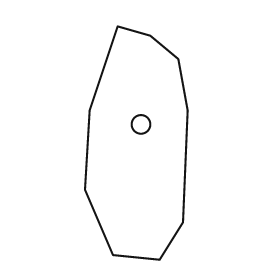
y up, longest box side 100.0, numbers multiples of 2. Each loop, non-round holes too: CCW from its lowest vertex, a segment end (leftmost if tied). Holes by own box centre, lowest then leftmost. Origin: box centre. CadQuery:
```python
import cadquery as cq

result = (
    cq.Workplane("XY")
    .moveTo(10.0, -50.0)
    .lineTo(20.0, -34.0)
    .lineTo(22.0, 14.0)
    .lineTo(18.0, 36.0)
    .lineTo(6.0, 46.0)
    .lineTo(-8.0, 50.0)
    .lineTo(-20.0, 14.0)
    .lineTo(-22.0, -20.0)
    .lineTo(-10.0, -48.0)
    .close()
    .moveTo(2.0, 8.0)
    .circle(4.0)
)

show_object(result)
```